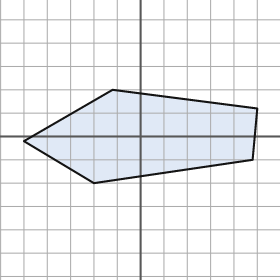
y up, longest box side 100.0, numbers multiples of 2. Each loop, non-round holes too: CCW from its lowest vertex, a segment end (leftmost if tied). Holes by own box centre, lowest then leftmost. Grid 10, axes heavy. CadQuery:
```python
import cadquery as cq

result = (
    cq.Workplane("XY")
    .moveTo(-20.0, -20.0)
    .lineTo(48.0, -10.0)
    .lineTo(50.0, 12.0)
    .lineTo(-12.0, 20.0)
    .lineTo(-50.0, -2.0)
    .close()
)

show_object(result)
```